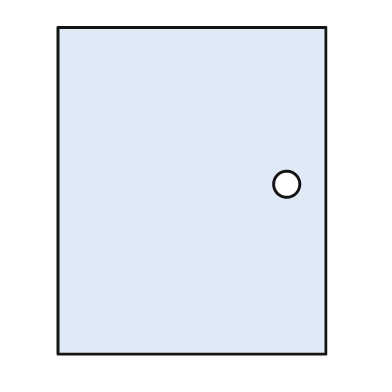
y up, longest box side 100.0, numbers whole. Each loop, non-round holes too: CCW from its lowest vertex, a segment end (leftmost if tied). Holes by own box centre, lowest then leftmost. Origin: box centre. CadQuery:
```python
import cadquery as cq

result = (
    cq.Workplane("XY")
    .moveTo(-41.0, -50.0)
    .lineTo(41.0, -50.0)
    .lineTo(41.0, 50.0)
    .lineTo(-41.0, 50.0)
    .close()
    .moveTo(29.0, 2.0)
    .circle(4.0)
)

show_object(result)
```